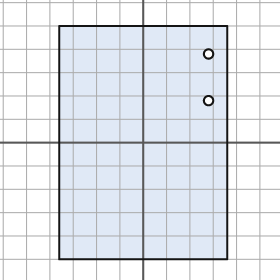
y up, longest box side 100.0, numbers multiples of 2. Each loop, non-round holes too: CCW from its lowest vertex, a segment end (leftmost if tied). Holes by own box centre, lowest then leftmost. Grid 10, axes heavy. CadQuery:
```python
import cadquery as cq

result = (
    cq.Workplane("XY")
    .moveTo(-36.0, -50.0)
    .lineTo(36.0, -50.0)
    .lineTo(36.0, 50.0)
    .lineTo(-36.0, 50.0)
    .close()
    .moveTo(28.0, 18.0)
    .circle(2.0)
    .moveTo(28.0, 38.0)
    .circle(2.0)
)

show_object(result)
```